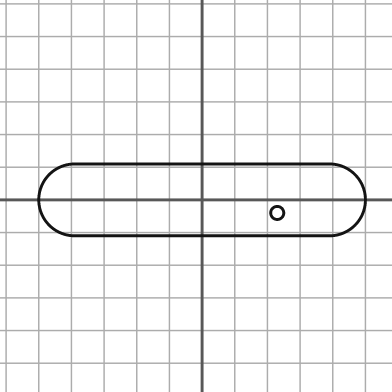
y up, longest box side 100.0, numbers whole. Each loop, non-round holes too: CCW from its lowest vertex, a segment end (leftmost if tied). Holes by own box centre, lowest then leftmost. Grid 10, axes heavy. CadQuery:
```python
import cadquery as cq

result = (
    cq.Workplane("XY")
    .moveTo(-39.0, -11.0)
    .lineTo(39.0, -11.0)
    .threePointArc((50.0, 0.0), (39.0, 11.0))
    .lineTo(-39.0, 11.0)
    .threePointArc((-50.0, 0.0), (-39.0, -11.0))
    .close()
    .moveTo(23.0, -4.0)
    .circle(2.0)
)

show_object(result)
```